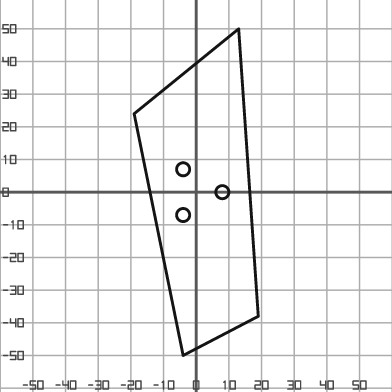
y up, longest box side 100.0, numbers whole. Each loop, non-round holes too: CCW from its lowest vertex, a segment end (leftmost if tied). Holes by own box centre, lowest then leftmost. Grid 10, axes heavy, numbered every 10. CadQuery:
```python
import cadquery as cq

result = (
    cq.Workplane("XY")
    .moveTo(-4.0, -50.0)
    .lineTo(19.0, -38.0)
    .lineTo(13.0, 50.0)
    .lineTo(-19.0, 24.0)
    .close()
    .moveTo(-4.0, -7.0)
    .circle(2.0)
    .moveTo(8.0, 0.0)
    .circle(2.0)
    .moveTo(-4.0, 7.0)
    .circle(2.0)
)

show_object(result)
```